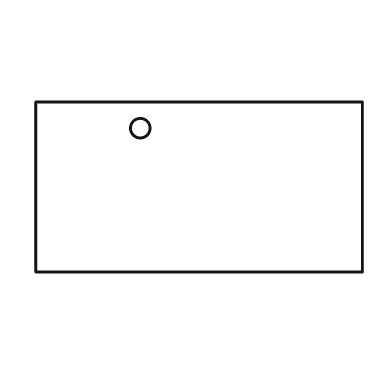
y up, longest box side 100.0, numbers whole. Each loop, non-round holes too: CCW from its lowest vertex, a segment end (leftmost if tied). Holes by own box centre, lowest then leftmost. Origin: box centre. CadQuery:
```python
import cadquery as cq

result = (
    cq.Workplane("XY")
    .moveTo(-50.0, -26.0)
    .lineTo(50.0, -26.0)
    .lineTo(50.0, 26.0)
    .lineTo(-50.0, 26.0)
    .close()
    .moveTo(-18.0, 18.0)
    .circle(3.0)
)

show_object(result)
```